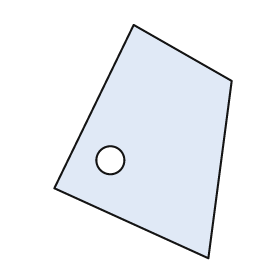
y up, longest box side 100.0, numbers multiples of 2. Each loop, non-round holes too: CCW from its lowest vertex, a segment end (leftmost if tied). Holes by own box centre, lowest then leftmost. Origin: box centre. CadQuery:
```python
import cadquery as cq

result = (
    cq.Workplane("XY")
    .moveTo(28.0, -50.0)
    .lineTo(38.0, 26.0)
    .lineTo(-4.0, 50.0)
    .lineTo(-38.0, -20.0)
    .close()
    .moveTo(-14.0, -8.0)
    .circle(6.0)
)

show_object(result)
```